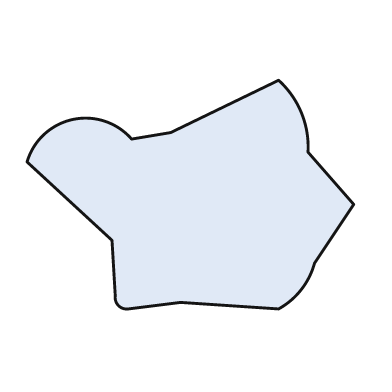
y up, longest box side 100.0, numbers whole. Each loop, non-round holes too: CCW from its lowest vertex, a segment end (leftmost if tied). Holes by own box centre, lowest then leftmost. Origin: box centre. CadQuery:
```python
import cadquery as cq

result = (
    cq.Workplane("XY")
    .moveTo(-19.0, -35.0)
    .lineTo(-3.0, -33.0)
    .lineTo(27.0, -35.0)
    .threePointArc((34.0, -29.0), (38.0, -21.0))
    .lineTo(50.0, -3.0)
    .lineTo(36.0, 13.0)
    .threePointArc((34.0, 25.0), (27.0, 35.0))
    .lineTo(-6.0, 19.0)
    .lineTo(-18.0, 17.0)
    .threePointArc((-36.0, 23.0), (-50.0, 10.0))
    .lineTo(-24.0, -14.0)
    .lineTo(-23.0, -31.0)
    .threePointArc((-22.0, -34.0), (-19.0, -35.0))
    .close()
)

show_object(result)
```